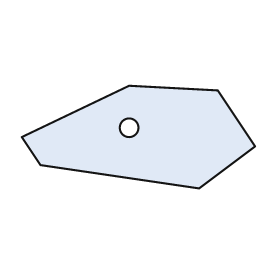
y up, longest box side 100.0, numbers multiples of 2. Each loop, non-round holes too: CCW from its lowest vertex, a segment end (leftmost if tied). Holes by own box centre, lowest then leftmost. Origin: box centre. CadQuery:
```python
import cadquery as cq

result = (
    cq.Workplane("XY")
    .moveTo(26.0, -22.0)
    .lineTo(50.0, -4.0)
    .lineTo(34.0, 20.0)
    .lineTo(-4.0, 22.0)
    .lineTo(-50.0, 0.0)
    .lineTo(-42.0, -12.0)
    .close()
    .moveTo(-4.0, 4.0)
    .circle(4.0)
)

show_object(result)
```